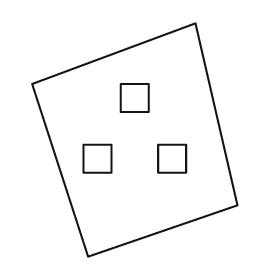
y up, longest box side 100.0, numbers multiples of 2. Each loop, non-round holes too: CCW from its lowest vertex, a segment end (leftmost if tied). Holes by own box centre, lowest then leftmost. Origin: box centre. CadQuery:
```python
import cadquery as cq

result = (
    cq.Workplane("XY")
    .moveTo(-20.0, -50.0)
    .lineTo(44.0, -28.0)
    .lineTo(26.0, 50.0)
    .lineTo(-44.0, 24.0)
    .close()
    .moveTo(-22.0, -14.0)
    .lineTo(-10.0, -14.0)
    .lineTo(-10.0, -2.0)
    .lineTo(-22.0, -2.0)
    .close()
    .moveTo(10.0, -14.0)
    .lineTo(22.0, -14.0)
    .lineTo(22.0, -2.0)
    .lineTo(10.0, -2.0)
    .close()
    .moveTo(-6.0, 12.0)
    .lineTo(6.0, 12.0)
    .lineTo(6.0, 24.0)
    .lineTo(-6.0, 24.0)
    .close()
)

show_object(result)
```